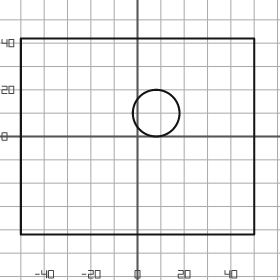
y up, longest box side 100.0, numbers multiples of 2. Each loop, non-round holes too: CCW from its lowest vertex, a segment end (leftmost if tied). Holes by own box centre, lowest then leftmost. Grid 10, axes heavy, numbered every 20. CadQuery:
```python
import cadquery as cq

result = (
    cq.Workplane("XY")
    .moveTo(-50.0, -42.0)
    .lineTo(50.0, -42.0)
    .lineTo(50.0, 42.0)
    .lineTo(-50.0, 42.0)
    .close()
    .moveTo(8.0, 10.0)
    .circle(10.0)
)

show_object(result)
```